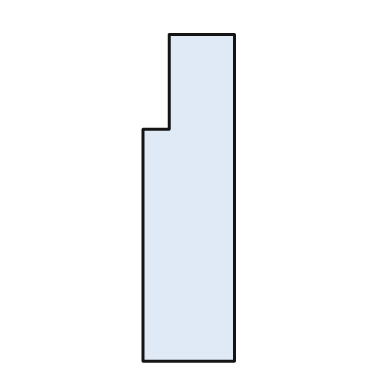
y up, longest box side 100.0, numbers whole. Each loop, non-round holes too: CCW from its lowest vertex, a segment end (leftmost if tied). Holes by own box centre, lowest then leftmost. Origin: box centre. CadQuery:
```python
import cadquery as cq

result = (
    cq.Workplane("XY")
    .moveTo(-14.0, -50.0)
    .lineTo(14.0, -50.0)
    .lineTo(14.0, 50.0)
    .lineTo(-6.0, 50.0)
    .lineTo(-6.0, 21.0)
    .lineTo(-14.0, 21.0)
    .close()
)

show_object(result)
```